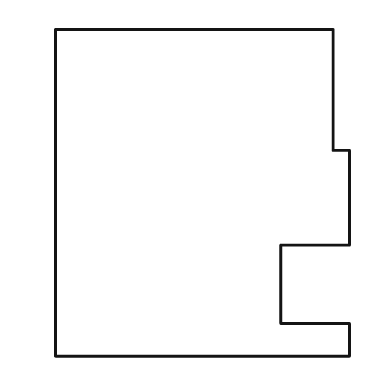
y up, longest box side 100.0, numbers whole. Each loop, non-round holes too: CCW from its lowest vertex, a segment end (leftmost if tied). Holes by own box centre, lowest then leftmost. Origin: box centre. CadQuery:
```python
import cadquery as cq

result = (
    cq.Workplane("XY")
    .moveTo(-45.0, -50.0)
    .lineTo(45.0, -50.0)
    .lineTo(45.0, -40.0)
    .lineTo(24.0, -40.0)
    .lineTo(24.0, -16.0)
    .lineTo(45.0, -16.0)
    .lineTo(45.0, 13.0)
    .lineTo(40.0, 13.0)
    .lineTo(40.0, 50.0)
    .lineTo(-45.0, 50.0)
    .close()
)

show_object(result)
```